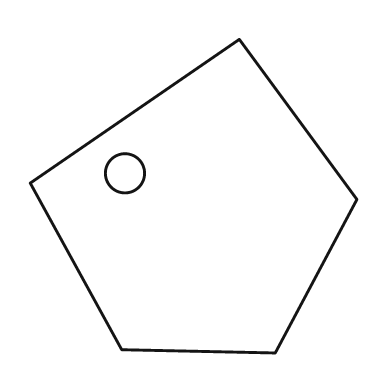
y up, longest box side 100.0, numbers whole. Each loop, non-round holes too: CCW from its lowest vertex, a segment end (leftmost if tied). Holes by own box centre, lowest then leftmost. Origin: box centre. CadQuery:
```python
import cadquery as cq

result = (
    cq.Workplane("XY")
    .moveTo(25.0, -48.0)
    .lineTo(50.0, -1.0)
    .lineTo(14.0, 48.0)
    .lineTo(-50.0, 4.0)
    .lineTo(-22.0, -47.0)
    .close()
    .moveTo(-21.0, 7.0)
    .circle(6.0)
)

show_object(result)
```